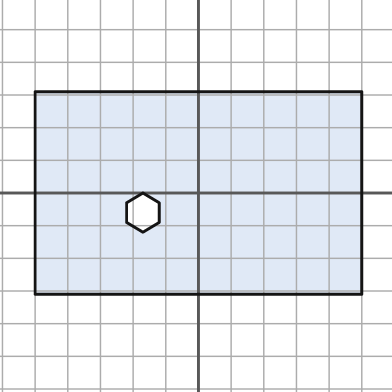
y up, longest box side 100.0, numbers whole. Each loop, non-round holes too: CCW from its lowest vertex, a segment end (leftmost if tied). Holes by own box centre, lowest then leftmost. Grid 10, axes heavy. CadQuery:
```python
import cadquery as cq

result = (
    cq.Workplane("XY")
    .moveTo(-50.0, -31.0)
    .lineTo(50.0, -31.0)
    .lineTo(50.0, 31.0)
    .lineTo(-50.0, 31.0)
    .close()
    .moveTo(-17.0, -12.0)
    .lineTo(-12.0, -9.0)
    .lineTo(-12.0, -3.0)
    .lineTo(-17.0, 0.0)
    .lineTo(-22.0, -3.0)
    .lineTo(-22.0, -9.0)
    .close()
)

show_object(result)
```